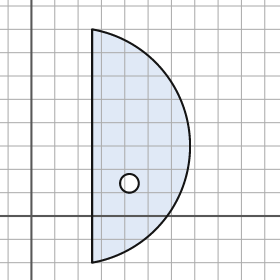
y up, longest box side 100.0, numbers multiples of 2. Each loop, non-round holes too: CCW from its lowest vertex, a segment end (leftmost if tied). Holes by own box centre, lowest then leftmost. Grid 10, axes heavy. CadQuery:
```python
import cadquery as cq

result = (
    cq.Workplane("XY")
    .moveTo(26.0, -20.0)
    .threePointArc((68.0, 30.0), (26.0, 80.0))
    .close()
    .moveTo(42.0, 14.0)
    .circle(4.0)
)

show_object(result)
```